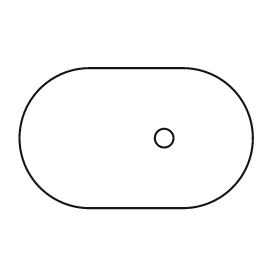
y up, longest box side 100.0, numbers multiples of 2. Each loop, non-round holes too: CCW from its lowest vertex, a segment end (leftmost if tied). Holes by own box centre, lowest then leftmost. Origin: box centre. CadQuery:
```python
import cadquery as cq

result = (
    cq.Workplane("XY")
    .moveTo(-20.0, -30.0)
    .lineTo(20.0, -30.0)
    .threePointArc((50.0, 0.0), (20.0, 30.0))
    .lineTo(-20.0, 30.0)
    .threePointArc((-50.0, 0.0), (-20.0, -30.0))
    .close()
    .moveTo(12.0, 0.0)
    .circle(4.0)
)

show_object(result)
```